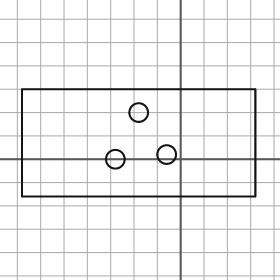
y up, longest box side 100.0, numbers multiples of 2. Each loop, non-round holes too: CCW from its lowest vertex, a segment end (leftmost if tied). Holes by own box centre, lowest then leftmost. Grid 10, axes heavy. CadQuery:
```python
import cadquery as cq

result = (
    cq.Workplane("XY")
    .moveTo(-68.0, -16.0)
    .lineTo(32.0, -16.0)
    .lineTo(32.0, 30.0)
    .lineTo(-68.0, 30.0)
    .close()
    .moveTo(-28.0, 0.0)
    .circle(4.0)
    .moveTo(-6.0, 2.0)
    .circle(4.0)
    .moveTo(-18.0, 20.0)
    .circle(4.0)
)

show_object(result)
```